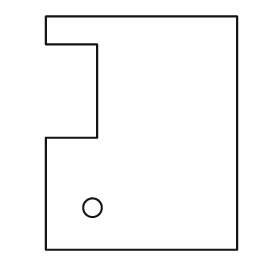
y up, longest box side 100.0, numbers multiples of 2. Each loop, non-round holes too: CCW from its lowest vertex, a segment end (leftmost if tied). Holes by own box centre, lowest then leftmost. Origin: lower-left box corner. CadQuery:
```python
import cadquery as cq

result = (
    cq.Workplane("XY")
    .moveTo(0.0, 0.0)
    .lineTo(82.0, 0.0)
    .lineTo(82.0, 100.0)
    .lineTo(0.0, 100.0)
    .lineTo(0.0, 88.0)
    .lineTo(22.0, 88.0)
    .lineTo(22.0, 48.0)
    .lineTo(0.0, 48.0)
    .close()
    .moveTo(20.0, 18.0)
    .circle(4.0)
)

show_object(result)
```